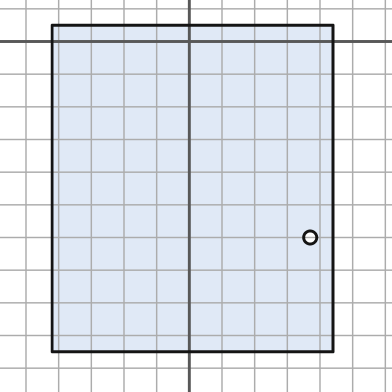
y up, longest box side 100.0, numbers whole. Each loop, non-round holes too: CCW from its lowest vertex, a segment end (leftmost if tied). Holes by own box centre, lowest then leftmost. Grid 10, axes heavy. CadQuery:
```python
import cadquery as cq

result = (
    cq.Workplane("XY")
    .moveTo(-42.0, -95.0)
    .lineTo(44.0, -95.0)
    .lineTo(44.0, 5.0)
    .lineTo(-42.0, 5.0)
    .close()
    .moveTo(37.0, -60.0)
    .circle(2.0)
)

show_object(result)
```